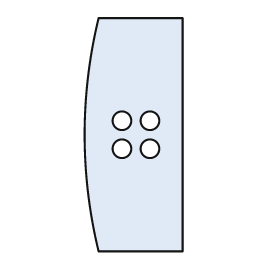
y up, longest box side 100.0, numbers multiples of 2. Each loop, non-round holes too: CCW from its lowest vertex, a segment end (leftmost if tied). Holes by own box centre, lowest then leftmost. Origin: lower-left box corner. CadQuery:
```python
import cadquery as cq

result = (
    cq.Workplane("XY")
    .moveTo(6.0, 0.0)
    .lineTo(42.0, 0.0)
    .lineTo(42.0, 100.0)
    .lineTo(6.0, 100.0)
    .threePointArc((0.0, 50.0), (6.0, 0.0))
    .close()
    .moveTo(16.0, 44.0)
    .circle(4.0)
    .moveTo(28.0, 44.0)
    .circle(4.0)
    .moveTo(16.0, 56.0)
    .circle(4.0)
    .moveTo(28.0, 56.0)
    .circle(4.0)
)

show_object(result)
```